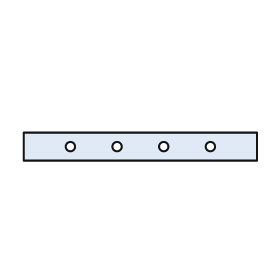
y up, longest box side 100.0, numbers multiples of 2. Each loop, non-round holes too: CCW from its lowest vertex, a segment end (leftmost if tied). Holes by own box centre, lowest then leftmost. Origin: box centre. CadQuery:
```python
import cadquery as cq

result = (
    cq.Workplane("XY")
    .moveTo(-50.0, -6.0)
    .lineTo(50.0, -6.0)
    .lineTo(50.0, 6.0)
    .lineTo(-50.0, 6.0)
    .close()
    .moveTo(-30.0, 0.0)
    .circle(2.0)
    .moveTo(-10.0, 0.0)
    .circle(2.0)
    .moveTo(10.0, 0.0)
    .circle(2.0)
    .moveTo(30.0, 0.0)
    .circle(2.0)
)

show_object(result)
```